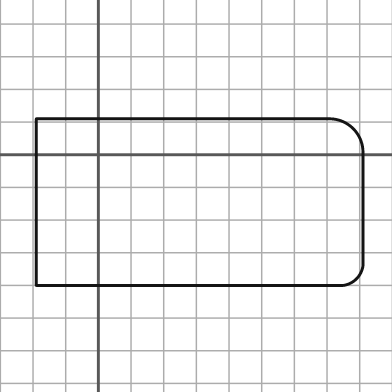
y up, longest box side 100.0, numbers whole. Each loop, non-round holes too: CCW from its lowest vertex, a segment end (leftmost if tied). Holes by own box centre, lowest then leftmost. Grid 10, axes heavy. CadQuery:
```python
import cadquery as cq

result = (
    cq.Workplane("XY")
    .moveTo(-19.0, -40.0)
    .lineTo(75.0, -40.0)
    .threePointArc((79.0, -38.0), (81.0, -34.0))
    .lineTo(81.0, 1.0)
    .threePointArc((78.0, 8.0), (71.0, 11.0))
    .lineTo(-19.0, 11.0)
    .close()
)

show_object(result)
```